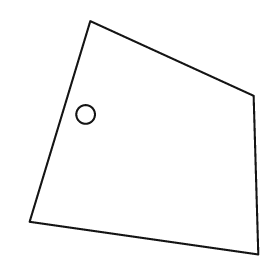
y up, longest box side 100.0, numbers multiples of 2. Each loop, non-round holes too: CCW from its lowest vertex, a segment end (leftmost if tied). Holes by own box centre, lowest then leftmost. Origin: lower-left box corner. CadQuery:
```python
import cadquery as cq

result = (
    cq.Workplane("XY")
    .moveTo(98.0, 0.0)
    .lineTo(96.0, 68.0)
    .lineTo(26.0, 100.0)
    .lineTo(0.0, 14.0)
    .close()
    .moveTo(24.0, 60.0)
    .circle(4.0)
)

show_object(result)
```